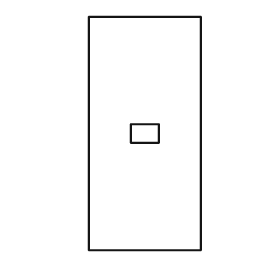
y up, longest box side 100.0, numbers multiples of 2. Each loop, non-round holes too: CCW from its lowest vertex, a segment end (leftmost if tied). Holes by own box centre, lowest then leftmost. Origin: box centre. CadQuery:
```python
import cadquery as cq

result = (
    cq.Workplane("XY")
    .moveTo(-24.0, -50.0)
    .lineTo(24.0, -50.0)
    .lineTo(24.0, 50.0)
    .lineTo(-24.0, 50.0)
    .close()
    .moveTo(-6.0, -4.0)
    .lineTo(6.0, -4.0)
    .lineTo(6.0, 4.0)
    .lineTo(-6.0, 4.0)
    .close()
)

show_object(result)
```